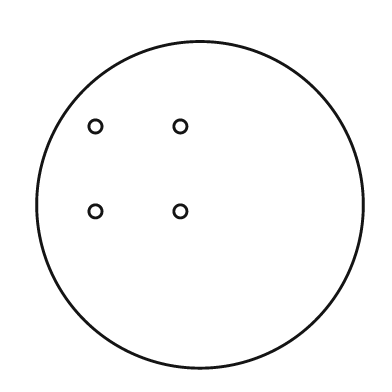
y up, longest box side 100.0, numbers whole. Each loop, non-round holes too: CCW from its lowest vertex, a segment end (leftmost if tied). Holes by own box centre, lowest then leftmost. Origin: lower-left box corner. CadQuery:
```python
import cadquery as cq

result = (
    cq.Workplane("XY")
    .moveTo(50.0, 50.0)
    .circle(50.0)
    .moveTo(18.0, 48.0)
    .circle(2.0)
    .moveTo(44.0, 48.0)
    .circle(2.0)
    .moveTo(18.0, 74.0)
    .circle(2.0)
    .moveTo(44.0, 74.0)
    .circle(2.0)
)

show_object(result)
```